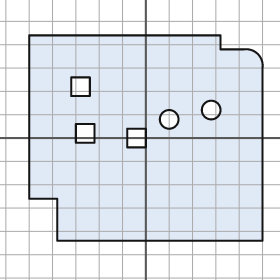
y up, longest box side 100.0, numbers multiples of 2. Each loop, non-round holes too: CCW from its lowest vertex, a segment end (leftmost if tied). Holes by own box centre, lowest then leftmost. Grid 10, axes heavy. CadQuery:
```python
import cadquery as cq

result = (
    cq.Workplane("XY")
    .moveTo(-38.0, -44.0)
    .lineTo(50.0, -44.0)
    .lineTo(50.0, 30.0)
    .threePointArc((48.0, 36.0), (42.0, 38.0))
    .lineTo(32.0, 38.0)
    .lineTo(32.0, 44.0)
    .lineTo(-50.0, 44.0)
    .lineTo(-50.0, -26.0)
    .lineTo(-38.0, -26.0)
    .close()
    .moveTo(-8.0, -4.0)
    .lineTo(0.0, -4.0)
    .lineTo(0.0, 4.0)
    .lineTo(-8.0, 4.0)
    .close()
    .moveTo(-30.0, -2.0)
    .lineTo(-22.0, -2.0)
    .lineTo(-22.0, 6.0)
    .lineTo(-30.0, 6.0)
    .close()
    .moveTo(10.0, 8.0)
    .circle(4.0)
    .moveTo(28.0, 12.0)
    .circle(4.0)
    .moveTo(-32.0, 18.0)
    .lineTo(-24.0, 18.0)
    .lineTo(-24.0, 26.0)
    .lineTo(-32.0, 26.0)
    .close()
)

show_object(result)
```